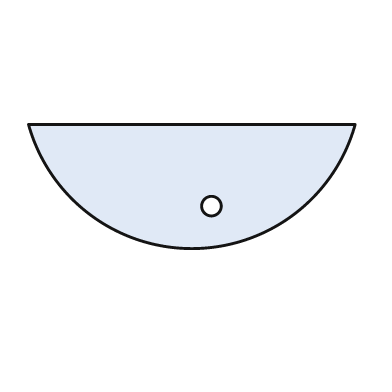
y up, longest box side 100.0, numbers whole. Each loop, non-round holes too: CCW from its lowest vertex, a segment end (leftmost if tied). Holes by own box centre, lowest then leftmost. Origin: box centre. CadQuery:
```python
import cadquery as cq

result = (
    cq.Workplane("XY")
    .moveTo(-50.0, 19.0)
    .threePointArc((0.0, -19.0), (50.0, 19.0))
    .close()
    .moveTo(6.0, -6.0)
    .circle(3.0)
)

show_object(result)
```